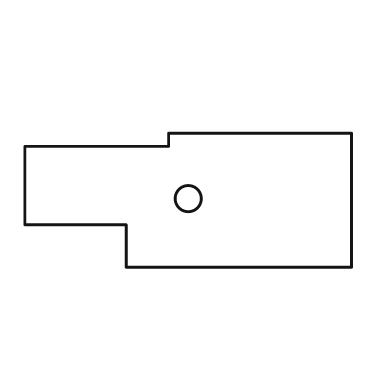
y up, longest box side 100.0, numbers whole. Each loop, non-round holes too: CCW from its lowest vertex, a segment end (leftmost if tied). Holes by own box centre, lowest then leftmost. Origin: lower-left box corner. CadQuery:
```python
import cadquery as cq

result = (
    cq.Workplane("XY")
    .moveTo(31.0, 0.0)
    .lineTo(100.0, 0.0)
    .lineTo(100.0, 41.0)
    .lineTo(44.0, 41.0)
    .lineTo(44.0, 37.0)
    .lineTo(0.0, 37.0)
    .lineTo(0.0, 13.0)
    .lineTo(31.0, 13.0)
    .close()
    .moveTo(50.0, 21.0)
    .circle(4.0)
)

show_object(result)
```